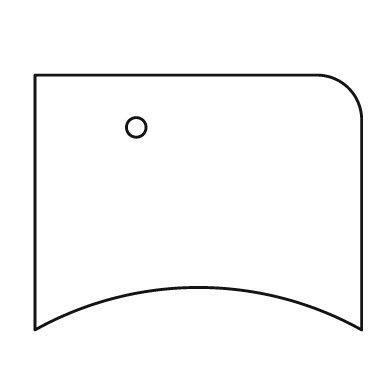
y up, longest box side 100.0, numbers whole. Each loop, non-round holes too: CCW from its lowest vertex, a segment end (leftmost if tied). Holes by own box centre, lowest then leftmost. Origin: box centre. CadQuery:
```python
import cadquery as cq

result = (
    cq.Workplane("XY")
    .moveTo(-50.0, -39.0)
    .threePointArc((0.0, -26.0), (50.0, -39.0))
    .lineTo(50.0, 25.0)
    .threePointArc((46.0, 35.0), (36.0, 39.0))
    .lineTo(-50.0, 39.0)
    .close()
    .moveTo(-19.0, 23.0)
    .circle(3.0)
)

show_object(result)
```